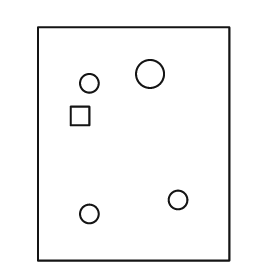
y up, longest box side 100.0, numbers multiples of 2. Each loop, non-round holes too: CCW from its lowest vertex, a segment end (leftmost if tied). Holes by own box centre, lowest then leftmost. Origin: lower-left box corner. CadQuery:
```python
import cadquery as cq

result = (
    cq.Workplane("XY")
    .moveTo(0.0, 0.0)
    .lineTo(82.0, 0.0)
    .lineTo(82.0, 100.0)
    .lineTo(0.0, 100.0)
    .close()
    .moveTo(22.0, 20.0)
    .circle(4.0)
    .moveTo(60.0, 26.0)
    .circle(4.0)
    .moveTo(14.0, 58.0)
    .lineTo(22.0, 58.0)
    .lineTo(22.0, 66.0)
    .lineTo(14.0, 66.0)
    .close()
    .moveTo(22.0, 76.0)
    .circle(4.0)
    .moveTo(48.0, 80.0)
    .circle(6.0)
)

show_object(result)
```